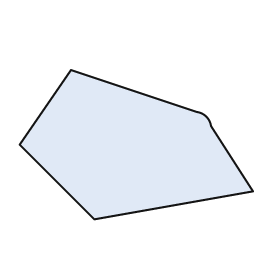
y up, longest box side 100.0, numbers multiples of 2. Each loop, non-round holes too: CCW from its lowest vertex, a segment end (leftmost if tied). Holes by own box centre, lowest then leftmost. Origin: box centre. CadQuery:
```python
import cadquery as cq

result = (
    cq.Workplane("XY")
    .moveTo(-18.0, -32.0)
    .lineTo(50.0, -20.0)
    .lineTo(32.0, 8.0)
    .threePointArc((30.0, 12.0), (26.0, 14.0))
    .lineTo(-28.0, 32.0)
    .lineTo(-50.0, 0.0)
    .close()
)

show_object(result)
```